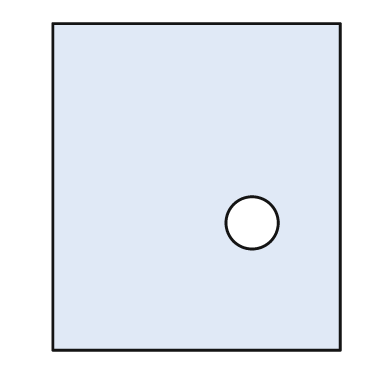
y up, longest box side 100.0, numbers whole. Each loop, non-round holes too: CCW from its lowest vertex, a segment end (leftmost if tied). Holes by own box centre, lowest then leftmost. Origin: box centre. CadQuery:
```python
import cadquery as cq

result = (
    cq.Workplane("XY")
    .moveTo(-44.0, -50.0)
    .lineTo(44.0, -50.0)
    .lineTo(44.0, 50.0)
    .lineTo(-44.0, 50.0)
    .close()
    .moveTo(17.0, -11.0)
    .circle(8.0)
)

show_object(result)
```